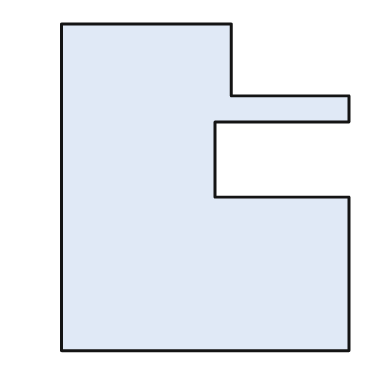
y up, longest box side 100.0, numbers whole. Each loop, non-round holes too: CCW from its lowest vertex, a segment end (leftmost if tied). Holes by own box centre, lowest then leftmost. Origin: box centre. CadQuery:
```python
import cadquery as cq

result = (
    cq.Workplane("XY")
    .moveTo(-44.0, -50.0)
    .lineTo(44.0, -50.0)
    .lineTo(44.0, -3.0)
    .lineTo(3.0, -3.0)
    .lineTo(3.0, 20.0)
    .lineTo(44.0, 20.0)
    .lineTo(44.0, 28.0)
    .lineTo(8.0, 28.0)
    .lineTo(8.0, 50.0)
    .lineTo(-44.0, 50.0)
    .close()
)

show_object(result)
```